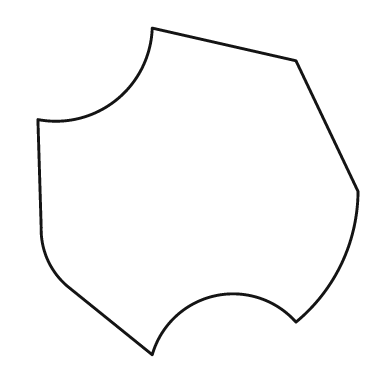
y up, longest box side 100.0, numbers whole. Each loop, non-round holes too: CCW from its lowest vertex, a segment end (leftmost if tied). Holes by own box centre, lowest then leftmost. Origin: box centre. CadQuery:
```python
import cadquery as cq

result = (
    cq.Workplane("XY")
    .moveTo(-14.0, -50.0)
    .threePointArc((5.0, -32.0), (30.0, -40.0))
    .threePointArc((44.0, -22.0), (49.0, 0.0))
    .lineTo(30.0, 40.0)
    .lineTo(-14.0, 50.0)
    .threePointArc((-25.0, 28.0), (-49.0, 22.0))
    .lineTo(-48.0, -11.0)
    .threePointArc((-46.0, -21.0), (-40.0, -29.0))
    .close()
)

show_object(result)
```